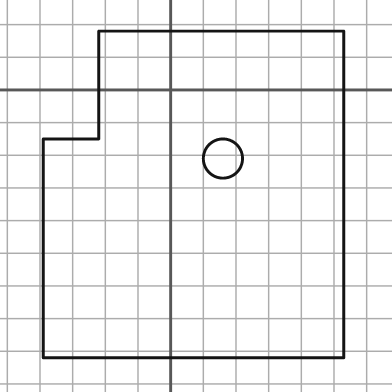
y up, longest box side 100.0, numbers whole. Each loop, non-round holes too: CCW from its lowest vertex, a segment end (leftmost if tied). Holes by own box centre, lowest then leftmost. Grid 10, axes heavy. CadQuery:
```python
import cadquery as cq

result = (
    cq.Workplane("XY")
    .moveTo(-39.0, -82.0)
    .lineTo(53.0, -82.0)
    .lineTo(53.0, 18.0)
    .lineTo(-22.0, 18.0)
    .lineTo(-22.0, -15.0)
    .lineTo(-39.0, -15.0)
    .close()
    .moveTo(16.0, -21.0)
    .circle(6.0)
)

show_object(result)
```